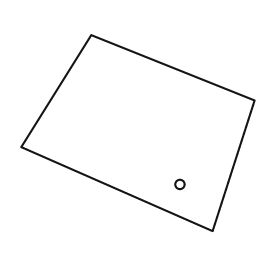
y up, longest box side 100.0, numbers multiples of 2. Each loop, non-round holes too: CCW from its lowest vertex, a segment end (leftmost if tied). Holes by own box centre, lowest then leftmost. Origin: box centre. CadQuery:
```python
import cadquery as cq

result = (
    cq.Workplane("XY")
    .moveTo(32.0, -42.0)
    .lineTo(50.0, 14.0)
    .lineTo(-20.0, 42.0)
    .lineTo(-50.0, -6.0)
    .close()
    .moveTo(18.0, -22.0)
    .circle(2.0)
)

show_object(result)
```